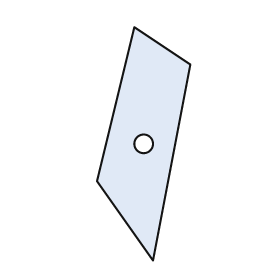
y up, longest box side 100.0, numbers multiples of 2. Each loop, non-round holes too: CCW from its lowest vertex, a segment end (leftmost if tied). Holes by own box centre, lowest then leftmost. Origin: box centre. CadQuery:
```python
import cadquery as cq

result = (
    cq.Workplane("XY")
    .moveTo(4.0, -50.0)
    .lineTo(20.0, 34.0)
    .lineTo(-4.0, 50.0)
    .lineTo(-20.0, -16.0)
    .close()
    .moveTo(0.0, 0.0)
    .circle(4.0)
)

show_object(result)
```